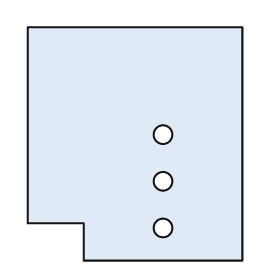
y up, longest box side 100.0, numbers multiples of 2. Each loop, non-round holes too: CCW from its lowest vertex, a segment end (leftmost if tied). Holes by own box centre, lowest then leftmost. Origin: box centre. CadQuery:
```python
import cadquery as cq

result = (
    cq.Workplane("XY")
    .moveTo(-22.0, -50.0)
    .lineTo(46.0, -50.0)
    .lineTo(46.0, 50.0)
    .lineTo(-46.0, 50.0)
    .lineTo(-46.0, -34.0)
    .lineTo(-22.0, -34.0)
    .close()
    .moveTo(12.0, -36.0)
    .circle(4.0)
    .moveTo(12.0, -16.0)
    .circle(4.0)
    .moveTo(12.0, 4.0)
    .circle(4.0)
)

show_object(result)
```